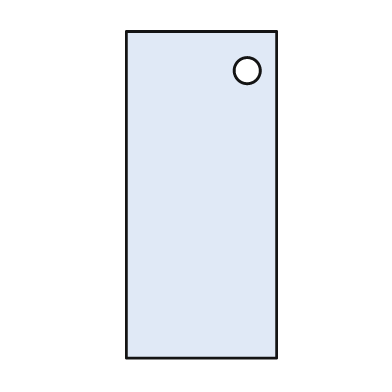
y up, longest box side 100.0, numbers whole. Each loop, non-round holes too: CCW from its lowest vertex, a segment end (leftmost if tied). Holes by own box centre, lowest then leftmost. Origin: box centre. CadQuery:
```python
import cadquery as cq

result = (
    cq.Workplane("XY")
    .moveTo(-23.0, -50.0)
    .lineTo(23.0, -50.0)
    .lineTo(23.0, 50.0)
    .lineTo(-23.0, 50.0)
    .close()
    .moveTo(14.0, 38.0)
    .circle(4.0)
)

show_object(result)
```